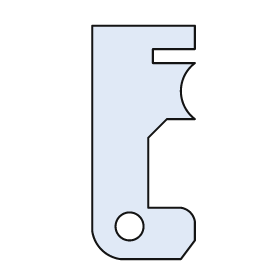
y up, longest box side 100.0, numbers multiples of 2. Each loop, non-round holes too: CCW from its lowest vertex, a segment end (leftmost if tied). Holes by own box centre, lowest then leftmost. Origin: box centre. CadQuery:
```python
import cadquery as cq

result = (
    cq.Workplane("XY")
    .moveTo(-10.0, -50.0)
    .lineTo(16.0, -50.0)
    .lineTo(22.0, -42.0)
    .lineTo(22.0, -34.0)
    .threePointArc((20.0, -30.0), (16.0, -28.0))
    .lineTo(2.0, -28.0)
    .lineTo(2.0, 2.0)
    .lineTo(10.0, 10.0)
    .lineTo(22.0, 10.0)
    .threePointArc((16.0, 22.0), (22.0, 34.0))
    .lineTo(4.0, 34.0)
    .lineTo(4.0, 40.0)
    .lineTo(22.0, 40.0)
    .lineTo(22.0, 50.0)
    .lineTo(-22.0, 50.0)
    .lineTo(-22.0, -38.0)
    .threePointArc((-18.0, -46.0), (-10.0, -50.0))
    .close()
    .moveTo(-6.0, -36.0)
    .circle(6.0)
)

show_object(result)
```